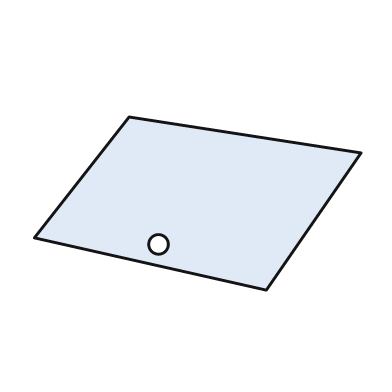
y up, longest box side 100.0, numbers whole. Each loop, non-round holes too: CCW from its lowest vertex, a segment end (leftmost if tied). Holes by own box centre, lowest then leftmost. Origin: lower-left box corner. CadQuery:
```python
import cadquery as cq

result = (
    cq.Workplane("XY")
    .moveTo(71.0, 0.0)
    .lineTo(100.0, 42.0)
    .lineTo(29.0, 53.0)
    .lineTo(0.0, 16.0)
    .close()
    .moveTo(38.0, 14.0)
    .circle(3.0)
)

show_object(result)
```